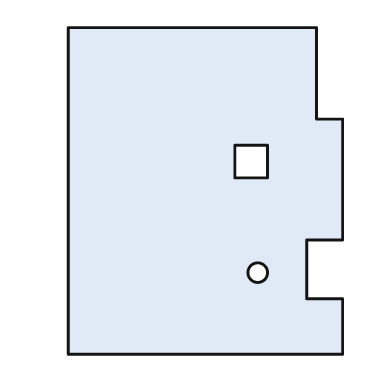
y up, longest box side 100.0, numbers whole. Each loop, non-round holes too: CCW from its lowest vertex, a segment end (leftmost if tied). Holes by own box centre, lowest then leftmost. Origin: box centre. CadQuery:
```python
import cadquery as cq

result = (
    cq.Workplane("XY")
    .moveTo(-42.0, -50.0)
    .lineTo(42.0, -50.0)
    .lineTo(42.0, -33.0)
    .lineTo(31.0, -33.0)
    .lineTo(31.0, -15.0)
    .lineTo(42.0, -15.0)
    .lineTo(42.0, 22.0)
    .lineTo(34.0, 22.0)
    .lineTo(34.0, 50.0)
    .lineTo(-42.0, 50.0)
    .close()
    .moveTo(16.0, -25.0)
    .circle(3.0)
    .moveTo(9.0, 4.0)
    .lineTo(19.0, 4.0)
    .lineTo(19.0, 14.0)
    .lineTo(9.0, 14.0)
    .close()
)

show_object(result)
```